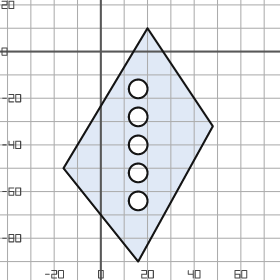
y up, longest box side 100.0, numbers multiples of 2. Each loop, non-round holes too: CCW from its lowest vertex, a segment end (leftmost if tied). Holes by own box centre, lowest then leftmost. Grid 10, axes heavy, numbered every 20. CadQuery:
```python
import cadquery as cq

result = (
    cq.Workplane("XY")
    .moveTo(16.0, -90.0)
    .lineTo(48.0, -32.0)
    .lineTo(20.0, 10.0)
    .lineTo(-16.0, -50.0)
    .close()
    .moveTo(16.0, -64.0)
    .circle(4.0)
    .moveTo(16.0, -52.0)
    .circle(4.0)
    .moveTo(16.0, -40.0)
    .circle(4.0)
    .moveTo(16.0, -28.0)
    .circle(4.0)
    .moveTo(16.0, -16.0)
    .circle(4.0)
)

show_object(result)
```